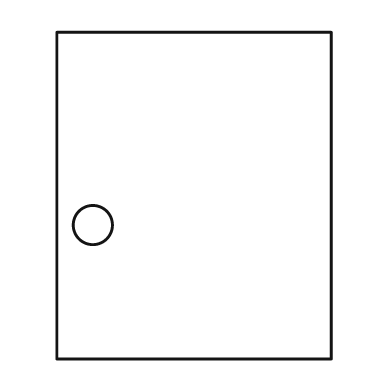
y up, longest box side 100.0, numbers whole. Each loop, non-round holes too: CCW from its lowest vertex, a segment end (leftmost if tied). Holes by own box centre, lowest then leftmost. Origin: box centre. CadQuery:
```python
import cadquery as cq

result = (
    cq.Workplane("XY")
    .moveTo(-42.0, -50.0)
    .lineTo(42.0, -50.0)
    .lineTo(42.0, 50.0)
    .lineTo(-42.0, 50.0)
    .close()
    .moveTo(-31.0, -9.0)
    .circle(6.0)
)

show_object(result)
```